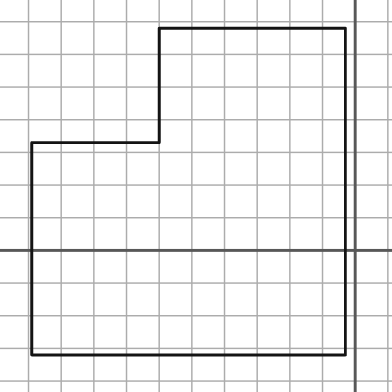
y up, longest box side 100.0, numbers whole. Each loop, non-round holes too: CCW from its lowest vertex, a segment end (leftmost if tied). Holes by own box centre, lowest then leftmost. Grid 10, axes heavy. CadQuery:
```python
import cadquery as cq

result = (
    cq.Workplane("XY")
    .moveTo(-99.0, -32.0)
    .lineTo(-3.0, -32.0)
    .lineTo(-3.0, 68.0)
    .lineTo(-60.0, 68.0)
    .lineTo(-60.0, 33.0)
    .lineTo(-99.0, 33.0)
    .close()
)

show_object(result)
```